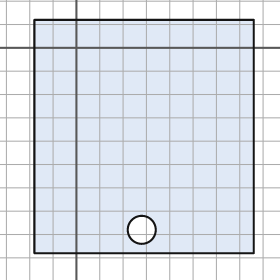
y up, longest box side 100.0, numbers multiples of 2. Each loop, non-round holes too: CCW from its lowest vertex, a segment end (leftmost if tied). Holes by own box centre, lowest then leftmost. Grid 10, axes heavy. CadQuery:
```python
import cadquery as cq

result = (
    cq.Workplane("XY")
    .moveTo(-18.0, -88.0)
    .lineTo(76.0, -88.0)
    .lineTo(76.0, 12.0)
    .lineTo(-18.0, 12.0)
    .close()
    .moveTo(28.0, -78.0)
    .circle(6.0)
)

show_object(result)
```